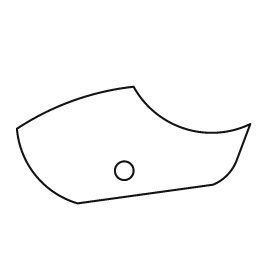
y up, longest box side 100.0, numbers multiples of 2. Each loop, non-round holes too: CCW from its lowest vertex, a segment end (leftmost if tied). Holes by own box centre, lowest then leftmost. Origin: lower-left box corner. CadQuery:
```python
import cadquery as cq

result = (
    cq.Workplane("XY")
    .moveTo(26.0, 0.0)
    .lineTo(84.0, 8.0)
    .threePointArc((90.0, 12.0), (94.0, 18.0))
    .lineTo(100.0, 34.0)
    .threePointArc((72.0, 32.0), (50.0, 50.0))
    .threePointArc((24.0, 44.0), (0.0, 32.0))
    .threePointArc((8.0, 12.0), (26.0, 0.0))
    .close()
    .moveTo(46.0, 14.0)
    .circle(4.0)
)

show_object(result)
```